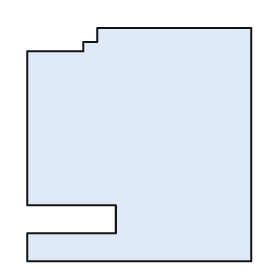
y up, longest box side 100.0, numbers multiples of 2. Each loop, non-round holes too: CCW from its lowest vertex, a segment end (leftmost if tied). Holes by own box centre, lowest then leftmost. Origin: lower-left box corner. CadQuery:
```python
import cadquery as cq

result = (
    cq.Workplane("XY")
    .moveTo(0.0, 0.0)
    .lineTo(96.0, 0.0)
    .lineTo(96.0, 100.0)
    .lineTo(30.0, 100.0)
    .lineTo(30.0, 94.0)
    .lineTo(24.0, 94.0)
    .lineTo(24.0, 90.0)
    .lineTo(0.0, 90.0)
    .lineTo(0.0, 24.0)
    .lineTo(38.0, 24.0)
    .lineTo(38.0, 12.0)
    .lineTo(0.0, 12.0)
    .close()
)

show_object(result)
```